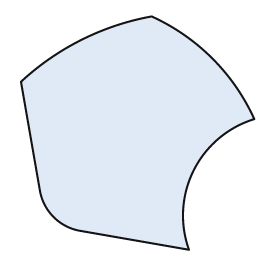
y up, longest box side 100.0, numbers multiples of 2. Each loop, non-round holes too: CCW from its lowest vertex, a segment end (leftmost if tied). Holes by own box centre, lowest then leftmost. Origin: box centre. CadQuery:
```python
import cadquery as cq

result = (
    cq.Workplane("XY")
    .moveTo(22.0, -50.0)
    .threePointArc((24.0, -16.0), (50.0, 6.0))
    .threePointArc((32.0, 32.0), (6.0, 50.0))
    .threePointArc((-24.0, 40.0), (-50.0, 22.0))
    .lineTo(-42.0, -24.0)
    .threePointArc((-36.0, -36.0), (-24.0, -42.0))
    .close()
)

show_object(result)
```